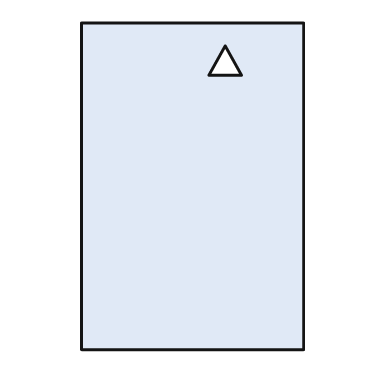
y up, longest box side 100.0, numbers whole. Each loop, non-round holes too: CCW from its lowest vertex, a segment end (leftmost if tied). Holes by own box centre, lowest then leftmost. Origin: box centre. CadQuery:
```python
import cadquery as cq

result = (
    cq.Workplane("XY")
    .moveTo(-34.0, -50.0)
    .lineTo(34.0, -50.0)
    .lineTo(34.0, 50.0)
    .lineTo(-34.0, 50.0)
    .close()
    .moveTo(5.0, 34.0)
    .lineTo(15.0, 34.0)
    .lineTo(10.0, 43.0)
    .close()
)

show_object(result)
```